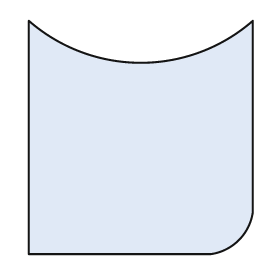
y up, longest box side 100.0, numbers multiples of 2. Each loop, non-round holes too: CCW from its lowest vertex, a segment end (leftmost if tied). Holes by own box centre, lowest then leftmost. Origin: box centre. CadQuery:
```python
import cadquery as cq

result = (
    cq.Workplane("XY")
    .moveTo(-48.0, -50.0)
    .lineTo(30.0, -50.0)
    .threePointArc((42.0, -44.0), (48.0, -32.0))
    .lineTo(48.0, 50.0)
    .threePointArc((0.0, 32.0), (-48.0, 50.0))
    .close()
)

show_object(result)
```